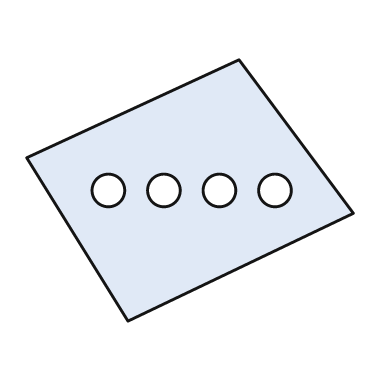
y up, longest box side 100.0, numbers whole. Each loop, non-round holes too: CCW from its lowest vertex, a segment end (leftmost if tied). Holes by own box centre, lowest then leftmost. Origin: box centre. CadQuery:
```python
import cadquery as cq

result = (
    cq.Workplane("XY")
    .moveTo(-19.0, -40.0)
    .lineTo(50.0, -7.0)
    .lineTo(15.0, 40.0)
    .lineTo(-50.0, 10.0)
    .close()
    .moveTo(-25.0, 0.0)
    .circle(5.0)
    .moveTo(-8.0, 0.0)
    .circle(5.0)
    .moveTo(9.0, 0.0)
    .circle(5.0)
    .moveTo(26.0, 0.0)
    .circle(5.0)
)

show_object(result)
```